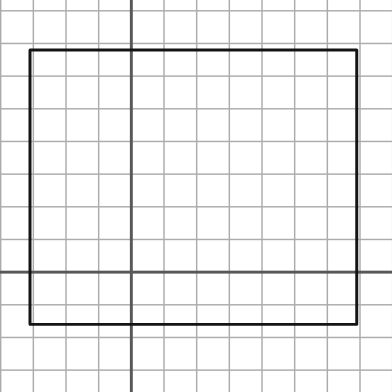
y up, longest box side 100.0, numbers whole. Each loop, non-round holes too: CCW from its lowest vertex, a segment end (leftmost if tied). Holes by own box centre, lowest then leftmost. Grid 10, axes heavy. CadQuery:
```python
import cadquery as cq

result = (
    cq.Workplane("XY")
    .moveTo(-31.0, -16.0)
    .lineTo(69.0, -16.0)
    .lineTo(69.0, 68.0)
    .lineTo(-31.0, 68.0)
    .close()
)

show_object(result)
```